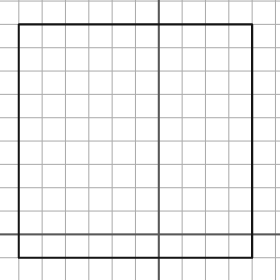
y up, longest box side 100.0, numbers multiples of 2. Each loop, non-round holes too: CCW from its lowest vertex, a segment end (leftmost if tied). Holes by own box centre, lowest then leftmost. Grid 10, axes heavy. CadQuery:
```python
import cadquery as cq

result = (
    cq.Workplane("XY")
    .moveTo(-60.0, -10.0)
    .lineTo(40.0, -10.0)
    .lineTo(40.0, 90.0)
    .lineTo(-60.0, 90.0)
    .close()
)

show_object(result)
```